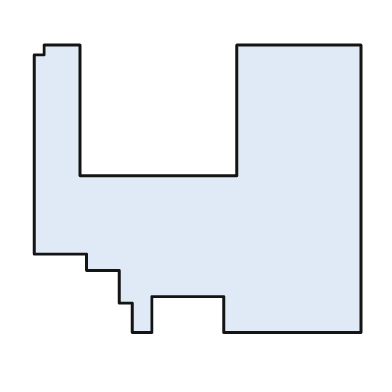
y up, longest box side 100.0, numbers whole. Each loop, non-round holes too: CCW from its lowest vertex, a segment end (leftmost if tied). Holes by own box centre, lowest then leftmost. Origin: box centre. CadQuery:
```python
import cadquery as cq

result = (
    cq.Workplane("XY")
    .moveTo(-20.0, -44.0)
    .lineTo(-14.0, -44.0)
    .lineTo(-14.0, -33.0)
    .lineTo(8.0, -33.0)
    .lineTo(8.0, -44.0)
    .lineTo(50.0, -44.0)
    .lineTo(50.0, 44.0)
    .lineTo(12.0, 44.0)
    .lineTo(12.0, 4.0)
    .lineTo(-36.0, 4.0)
    .lineTo(-36.0, 44.0)
    .lineTo(-47.0, 44.0)
    .lineTo(-47.0, 41.0)
    .lineTo(-50.0, 41.0)
    .lineTo(-50.0, -20.0)
    .lineTo(-34.0, -20.0)
    .lineTo(-34.0, -25.0)
    .lineTo(-24.0, -25.0)
    .lineTo(-24.0, -35.0)
    .lineTo(-20.0, -35.0)
    .close()
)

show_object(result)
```